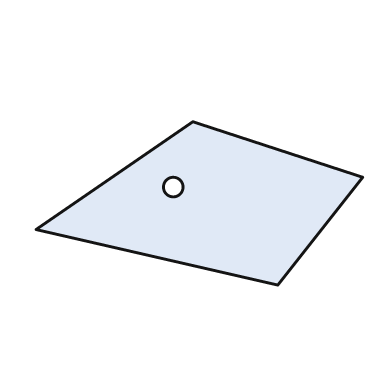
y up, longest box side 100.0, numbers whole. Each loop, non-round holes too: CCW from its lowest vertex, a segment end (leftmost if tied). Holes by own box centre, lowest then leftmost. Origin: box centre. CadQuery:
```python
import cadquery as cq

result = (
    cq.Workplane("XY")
    .moveTo(24.0, -25.0)
    .lineTo(50.0, 8.0)
    .lineTo(-2.0, 25.0)
    .lineTo(-50.0, -8.0)
    .close()
    .moveTo(-8.0, 5.0)
    .circle(3.0)
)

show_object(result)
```